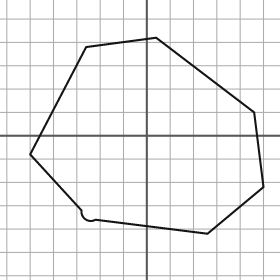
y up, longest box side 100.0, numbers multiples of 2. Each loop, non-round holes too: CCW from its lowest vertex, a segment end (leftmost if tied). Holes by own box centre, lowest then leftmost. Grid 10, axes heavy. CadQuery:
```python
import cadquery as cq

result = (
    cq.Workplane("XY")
    .moveTo(26.0, -42.0)
    .lineTo(50.0, -22.0)
    .lineTo(46.0, 10.0)
    .lineTo(4.0, 42.0)
    .lineTo(-26.0, 38.0)
    .lineTo(-50.0, -8.0)
    .lineTo(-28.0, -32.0)
    .threePointArc((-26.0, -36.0), (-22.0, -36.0))
    .close()
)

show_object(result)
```